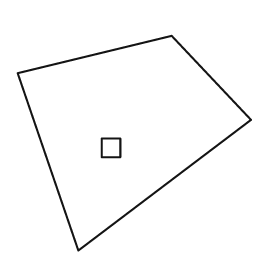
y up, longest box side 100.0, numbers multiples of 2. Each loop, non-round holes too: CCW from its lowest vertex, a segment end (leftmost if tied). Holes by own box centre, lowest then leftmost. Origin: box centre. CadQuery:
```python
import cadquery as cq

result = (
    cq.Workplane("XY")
    .moveTo(-24.0, -46.0)
    .lineTo(50.0, 10.0)
    .lineTo(16.0, 46.0)
    .lineTo(-50.0, 30.0)
    .close()
    .moveTo(-14.0, -6.0)
    .lineTo(-6.0, -6.0)
    .lineTo(-6.0, 2.0)
    .lineTo(-14.0, 2.0)
    .close()
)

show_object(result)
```